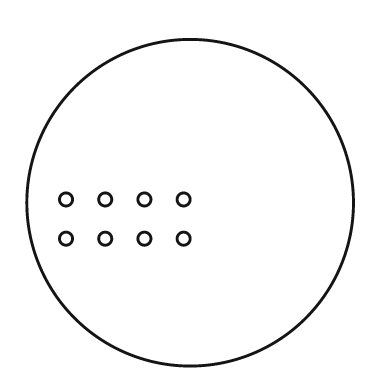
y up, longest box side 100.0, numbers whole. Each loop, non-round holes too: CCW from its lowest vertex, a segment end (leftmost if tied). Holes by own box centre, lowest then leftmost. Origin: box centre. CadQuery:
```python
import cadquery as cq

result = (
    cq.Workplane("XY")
    .moveTo(0.0, 0.0)
    .circle(50.0)
    .moveTo(-38.0, -11.0)
    .circle(2.0)
    .moveTo(-26.0, -11.0)
    .circle(2.0)
    .moveTo(-14.0, -11.0)
    .circle(2.0)
    .moveTo(-2.0, -11.0)
    .circle(2.0)
    .moveTo(-38.0, 1.0)
    .circle(2.0)
    .moveTo(-26.0, 1.0)
    .circle(2.0)
    .moveTo(-14.0, 1.0)
    .circle(2.0)
    .moveTo(-2.0, 1.0)
    .circle(2.0)
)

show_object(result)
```